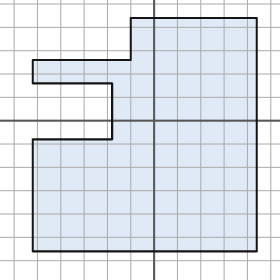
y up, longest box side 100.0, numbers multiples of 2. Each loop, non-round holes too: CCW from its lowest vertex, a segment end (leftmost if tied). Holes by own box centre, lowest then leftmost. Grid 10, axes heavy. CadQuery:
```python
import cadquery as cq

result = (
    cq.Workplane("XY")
    .moveTo(-52.0, -56.0)
    .lineTo(44.0, -56.0)
    .lineTo(44.0, 44.0)
    .lineTo(-10.0, 44.0)
    .lineTo(-10.0, 26.0)
    .lineTo(-52.0, 26.0)
    .lineTo(-52.0, 16.0)
    .lineTo(-18.0, 16.0)
    .lineTo(-18.0, -8.0)
    .lineTo(-52.0, -8.0)
    .close()
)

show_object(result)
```